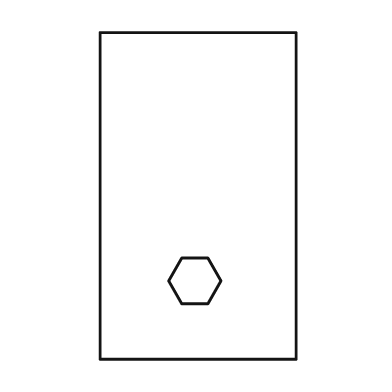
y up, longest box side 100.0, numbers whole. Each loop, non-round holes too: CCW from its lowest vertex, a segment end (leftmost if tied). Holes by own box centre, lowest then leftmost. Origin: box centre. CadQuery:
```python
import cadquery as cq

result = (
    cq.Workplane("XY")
    .moveTo(-30.0, -50.0)
    .lineTo(30.0, -50.0)
    .lineTo(30.0, 50.0)
    .lineTo(-30.0, 50.0)
    .close()
    .moveTo(-5.0, -33.0)
    .lineTo(3.0, -33.0)
    .lineTo(7.0, -26.0)
    .lineTo(3.0, -19.0)
    .lineTo(-5.0, -19.0)
    .lineTo(-9.0, -26.0)
    .close()
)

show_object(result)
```